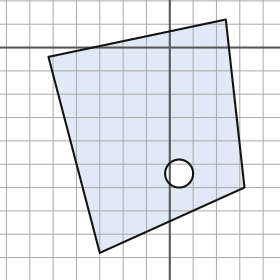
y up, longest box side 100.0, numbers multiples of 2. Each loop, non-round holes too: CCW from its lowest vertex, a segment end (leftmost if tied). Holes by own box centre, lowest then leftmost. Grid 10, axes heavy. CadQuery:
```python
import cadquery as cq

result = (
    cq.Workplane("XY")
    .moveTo(-30.0, -88.0)
    .lineTo(32.0, -60.0)
    .lineTo(24.0, 12.0)
    .lineTo(-52.0, -4.0)
    .close()
    .moveTo(4.0, -54.0)
    .circle(6.0)
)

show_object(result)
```